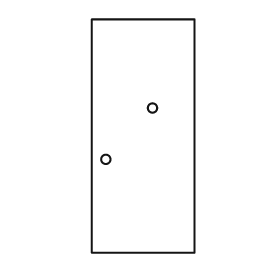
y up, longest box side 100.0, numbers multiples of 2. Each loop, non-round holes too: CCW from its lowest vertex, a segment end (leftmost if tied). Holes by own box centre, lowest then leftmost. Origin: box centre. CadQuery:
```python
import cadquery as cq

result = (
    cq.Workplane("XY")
    .moveTo(-22.0, -50.0)
    .lineTo(22.0, -50.0)
    .lineTo(22.0, 50.0)
    .lineTo(-22.0, 50.0)
    .close()
    .moveTo(-16.0, -10.0)
    .circle(2.0)
    .moveTo(4.0, 12.0)
    .circle(2.0)
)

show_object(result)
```